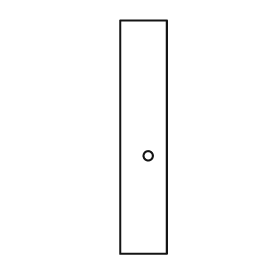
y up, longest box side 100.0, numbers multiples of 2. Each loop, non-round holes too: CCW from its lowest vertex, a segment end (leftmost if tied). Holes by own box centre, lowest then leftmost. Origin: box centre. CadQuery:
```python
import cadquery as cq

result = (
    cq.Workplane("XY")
    .moveTo(-10.0, -50.0)
    .lineTo(10.0, -50.0)
    .lineTo(10.0, 50.0)
    .lineTo(-10.0, 50.0)
    .close()
    .moveTo(2.0, -8.0)
    .circle(2.0)
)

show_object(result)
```